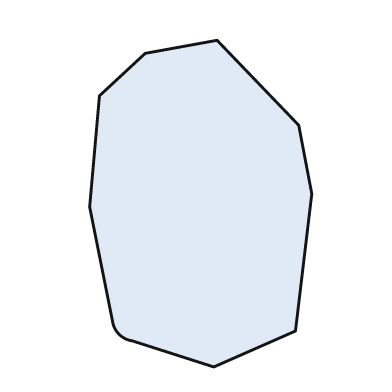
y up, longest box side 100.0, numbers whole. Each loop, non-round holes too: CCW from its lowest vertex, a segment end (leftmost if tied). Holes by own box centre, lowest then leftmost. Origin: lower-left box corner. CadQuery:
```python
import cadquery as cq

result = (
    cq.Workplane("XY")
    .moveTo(38.0, 0.0)
    .lineTo(63.0, 11.0)
    .lineTo(68.0, 53.0)
    .lineTo(64.0, 74.0)
    .lineTo(39.0, 100.0)
    .lineTo(17.0, 96.0)
    .lineTo(3.0, 83.0)
    .lineTo(0.0, 49.0)
    .lineTo(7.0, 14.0)
    .threePointArc((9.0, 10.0), (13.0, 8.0))
    .close()
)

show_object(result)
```